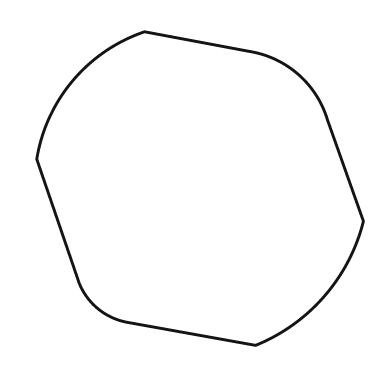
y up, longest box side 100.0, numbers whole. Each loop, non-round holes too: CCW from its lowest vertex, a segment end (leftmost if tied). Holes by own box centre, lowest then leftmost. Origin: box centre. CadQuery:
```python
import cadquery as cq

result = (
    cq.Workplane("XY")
    .moveTo(17.0, -48.0)
    .threePointArc((38.0, -33.0), (50.0, -10.0))
    .lineTo(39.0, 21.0)
    .threePointArc((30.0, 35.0), (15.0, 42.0))
    .lineTo(-17.0, 48.0)
    .threePointArc((-39.0, 33.0), (-50.0, 9.0))
    .lineTo(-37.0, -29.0)
    .threePointArc((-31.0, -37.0), (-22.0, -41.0))
    .close()
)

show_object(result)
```